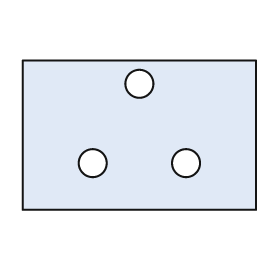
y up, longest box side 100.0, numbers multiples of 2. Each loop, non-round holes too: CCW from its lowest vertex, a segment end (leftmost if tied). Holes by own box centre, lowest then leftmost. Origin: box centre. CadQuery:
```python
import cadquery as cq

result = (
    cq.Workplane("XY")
    .moveTo(-50.0, -32.0)
    .lineTo(50.0, -32.0)
    .lineTo(50.0, 32.0)
    .lineTo(-50.0, 32.0)
    .close()
    .moveTo(-20.0, -12.0)
    .circle(6.0)
    .moveTo(20.0, -12.0)
    .circle(6.0)
    .moveTo(0.0, 22.0)
    .circle(6.0)
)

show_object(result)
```